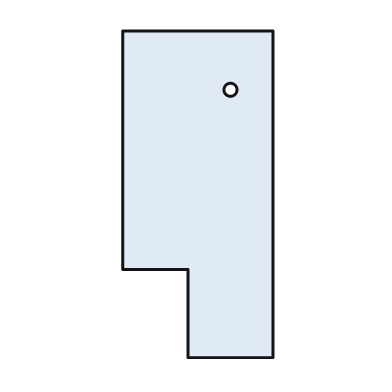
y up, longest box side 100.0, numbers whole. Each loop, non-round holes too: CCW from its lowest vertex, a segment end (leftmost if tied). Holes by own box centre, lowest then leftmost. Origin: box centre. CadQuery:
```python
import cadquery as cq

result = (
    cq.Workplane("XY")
    .moveTo(-3.0, -50.0)
    .lineTo(23.0, -50.0)
    .lineTo(23.0, 50.0)
    .lineTo(-23.0, 50.0)
    .lineTo(-23.0, -23.0)
    .lineTo(-3.0, -23.0)
    .close()
    .moveTo(10.0, 32.0)
    .circle(2.0)
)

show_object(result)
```